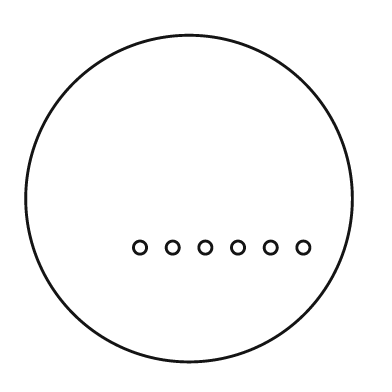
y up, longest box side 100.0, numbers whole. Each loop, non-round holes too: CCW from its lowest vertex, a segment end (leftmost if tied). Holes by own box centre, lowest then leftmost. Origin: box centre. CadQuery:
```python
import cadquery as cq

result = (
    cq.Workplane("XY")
    .moveTo(0.0, 0.0)
    .circle(50.0)
    .moveTo(-15.0, -15.0)
    .circle(2.0)
    .moveTo(-5.0, -15.0)
    .circle(2.0)
    .moveTo(5.0, -15.0)
    .circle(2.0)
    .moveTo(15.0, -15.0)
    .circle(2.0)
    .moveTo(25.0, -15.0)
    .circle(2.0)
    .moveTo(35.0, -15.0)
    .circle(2.0)
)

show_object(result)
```